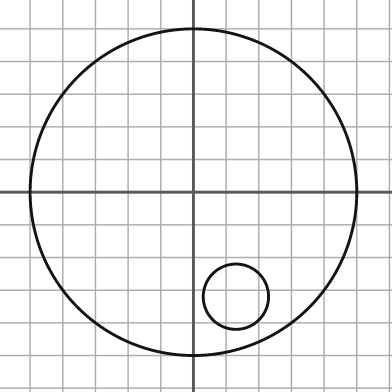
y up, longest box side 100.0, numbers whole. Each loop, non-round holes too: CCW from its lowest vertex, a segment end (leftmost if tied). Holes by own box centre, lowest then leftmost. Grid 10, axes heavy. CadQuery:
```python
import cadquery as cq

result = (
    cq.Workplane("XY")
    .moveTo(0.0, 0.0)
    .circle(50.0)
    .moveTo(13.0, -32.0)
    .circle(10.0)
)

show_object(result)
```